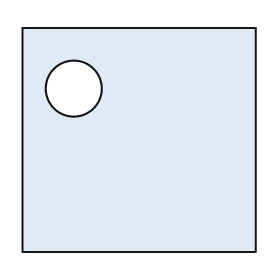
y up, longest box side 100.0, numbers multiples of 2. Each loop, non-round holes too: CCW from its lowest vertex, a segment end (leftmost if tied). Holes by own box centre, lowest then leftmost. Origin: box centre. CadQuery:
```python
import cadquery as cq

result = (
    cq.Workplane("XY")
    .moveTo(-50.0, -48.0)
    .lineTo(50.0, -48.0)
    .lineTo(50.0, 48.0)
    .lineTo(-50.0, 48.0)
    .close()
    .moveTo(-28.0, 22.0)
    .circle(12.0)
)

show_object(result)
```